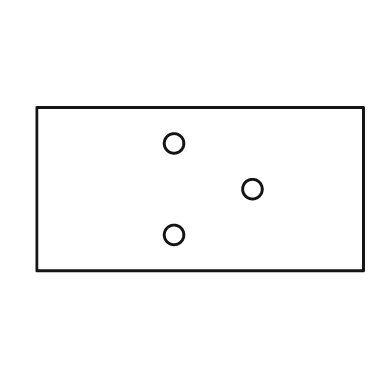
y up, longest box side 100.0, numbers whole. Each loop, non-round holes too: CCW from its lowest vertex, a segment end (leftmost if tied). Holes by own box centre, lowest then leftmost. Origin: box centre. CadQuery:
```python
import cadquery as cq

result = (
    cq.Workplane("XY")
    .moveTo(-50.0, -25.0)
    .lineTo(50.0, -25.0)
    .lineTo(50.0, 25.0)
    .lineTo(-50.0, 25.0)
    .close()
    .moveTo(-8.0, -14.0)
    .circle(3.0)
    .moveTo(16.0, 0.0)
    .circle(3.0)
    .moveTo(-8.0, 14.0)
    .circle(3.0)
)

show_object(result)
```